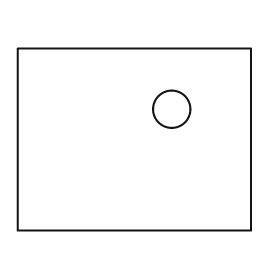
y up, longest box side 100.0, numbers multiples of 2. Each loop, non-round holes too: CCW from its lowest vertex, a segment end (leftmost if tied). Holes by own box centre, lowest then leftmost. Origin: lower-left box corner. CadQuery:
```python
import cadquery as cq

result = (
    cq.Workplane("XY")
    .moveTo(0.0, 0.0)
    .lineTo(100.0, 0.0)
    .lineTo(100.0, 78.0)
    .lineTo(0.0, 78.0)
    .close()
    .moveTo(66.0, 52.0)
    .circle(8.0)
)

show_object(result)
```